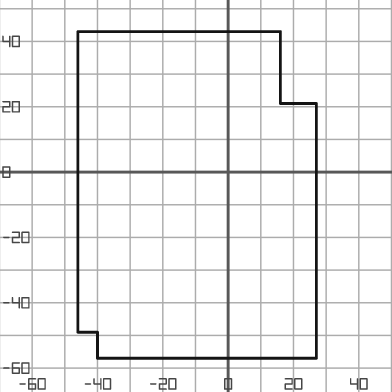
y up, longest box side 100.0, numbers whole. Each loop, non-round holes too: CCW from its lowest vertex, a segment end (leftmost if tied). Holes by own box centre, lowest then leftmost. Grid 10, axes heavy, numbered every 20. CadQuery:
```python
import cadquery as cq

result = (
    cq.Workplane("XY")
    .moveTo(-40.0, -57.0)
    .lineTo(27.0, -57.0)
    .lineTo(27.0, 21.0)
    .lineTo(16.0, 21.0)
    .lineTo(16.0, 43.0)
    .lineTo(-46.0, 43.0)
    .lineTo(-46.0, -49.0)
    .lineTo(-40.0, -49.0)
    .close()
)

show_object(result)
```